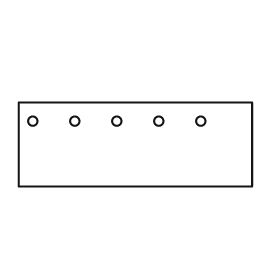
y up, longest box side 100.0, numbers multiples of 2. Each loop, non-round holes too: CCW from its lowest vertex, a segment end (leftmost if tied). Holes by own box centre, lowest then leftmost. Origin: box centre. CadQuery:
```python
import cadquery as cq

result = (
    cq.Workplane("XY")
    .moveTo(-50.0, -18.0)
    .lineTo(50.0, -18.0)
    .lineTo(50.0, 18.0)
    .lineTo(-50.0, 18.0)
    .close()
    .moveTo(-44.0, 10.0)
    .circle(2.0)
    .moveTo(-26.0, 10.0)
    .circle(2.0)
    .moveTo(-8.0, 10.0)
    .circle(2.0)
    .moveTo(10.0, 10.0)
    .circle(2.0)
    .moveTo(28.0, 10.0)
    .circle(2.0)
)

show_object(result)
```